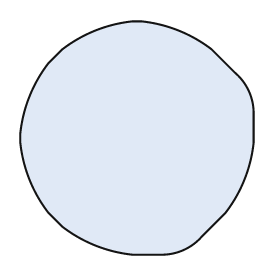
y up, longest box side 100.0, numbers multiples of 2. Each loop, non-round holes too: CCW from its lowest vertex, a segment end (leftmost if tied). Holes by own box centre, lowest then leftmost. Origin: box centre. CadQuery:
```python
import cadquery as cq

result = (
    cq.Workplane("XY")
    .moveTo(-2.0, -50.0)
    .lineTo(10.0, -50.0)
    .threePointArc((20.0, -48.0), (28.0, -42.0))
    .lineTo(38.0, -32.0)
    .threePointArc((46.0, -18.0), (50.0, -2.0))
    .lineTo(50.0, 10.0)
    .threePointArc((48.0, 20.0), (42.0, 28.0))
    .lineTo(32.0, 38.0)
    .threePointArc((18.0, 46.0), (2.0, 50.0))
    .lineTo(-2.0, 50.0)
    .threePointArc((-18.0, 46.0), (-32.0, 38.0))
    .lineTo(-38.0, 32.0)
    .threePointArc((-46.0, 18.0), (-50.0, 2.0))
    .lineTo(-50.0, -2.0)
    .threePointArc((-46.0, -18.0), (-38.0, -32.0))
    .lineTo(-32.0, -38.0)
    .threePointArc((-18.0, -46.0), (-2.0, -50.0))
    .close()
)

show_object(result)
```